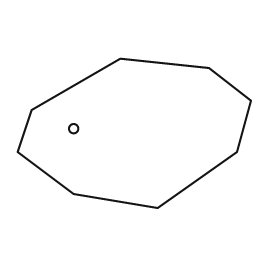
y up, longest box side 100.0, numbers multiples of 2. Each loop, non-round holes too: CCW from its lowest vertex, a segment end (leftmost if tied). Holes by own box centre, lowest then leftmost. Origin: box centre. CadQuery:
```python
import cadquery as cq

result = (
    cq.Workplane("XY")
    .moveTo(10.0, -32.0)
    .lineTo(44.0, -8.0)
    .lineTo(50.0, 14.0)
    .lineTo(32.0, 28.0)
    .lineTo(-6.0, 32.0)
    .lineTo(-44.0, 10.0)
    .lineTo(-50.0, -8.0)
    .lineTo(-26.0, -26.0)
    .close()
    .moveTo(-26.0, 2.0)
    .circle(2.0)
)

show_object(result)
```